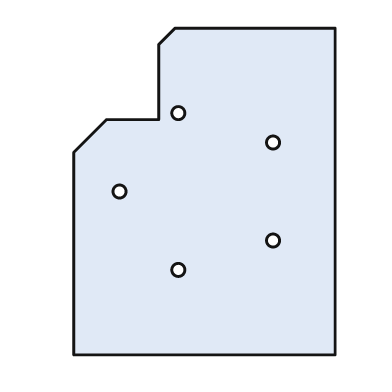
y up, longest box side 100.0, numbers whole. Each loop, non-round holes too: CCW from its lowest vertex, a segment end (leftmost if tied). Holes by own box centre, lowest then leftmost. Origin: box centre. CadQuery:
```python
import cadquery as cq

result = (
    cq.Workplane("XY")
    .moveTo(-40.0, -50.0)
    .lineTo(40.0, -50.0)
    .lineTo(40.0, 50.0)
    .lineTo(-9.0, 50.0)
    .lineTo(-14.0, 45.0)
    .lineTo(-14.0, 22.0)
    .lineTo(-30.0, 22.0)
    .lineTo(-40.0, 12.0)
    .close()
    .moveTo(-8.0, -24.0)
    .circle(2.0)
    .moveTo(21.0, -15.0)
    .circle(2.0)
    .moveTo(-26.0, 0.0)
    .circle(2.0)
    .moveTo(21.0, 15.0)
    .circle(2.0)
    .moveTo(-8.0, 24.0)
    .circle(2.0)
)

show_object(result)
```